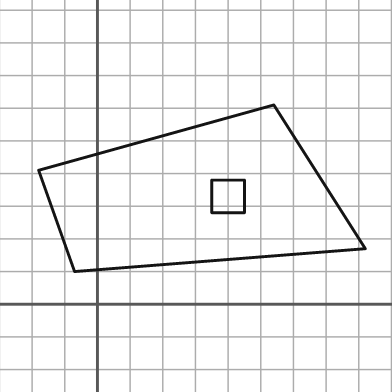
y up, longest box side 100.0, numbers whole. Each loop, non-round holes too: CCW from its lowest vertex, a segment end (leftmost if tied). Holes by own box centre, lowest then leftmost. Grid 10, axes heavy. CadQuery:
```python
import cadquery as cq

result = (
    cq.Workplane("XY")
    .moveTo(-7.0, 10.0)
    .lineTo(82.0, 17.0)
    .lineTo(54.0, 61.0)
    .lineTo(-18.0, 41.0)
    .close()
    .moveTo(35.0, 28.0)
    .lineTo(45.0, 28.0)
    .lineTo(45.0, 38.0)
    .lineTo(35.0, 38.0)
    .close()
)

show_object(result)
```